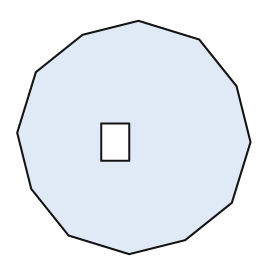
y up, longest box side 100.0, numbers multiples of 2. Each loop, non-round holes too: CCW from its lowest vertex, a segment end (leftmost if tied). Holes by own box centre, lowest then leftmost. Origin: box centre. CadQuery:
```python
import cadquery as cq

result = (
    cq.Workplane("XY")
    .moveTo(-2.0, -50.0)
    .lineTo(22.0, -44.0)
    .lineTo(42.0, -28.0)
    .lineTo(50.0, -2.0)
    .lineTo(44.0, 22.0)
    .lineTo(28.0, 42.0)
    .lineTo(2.0, 50.0)
    .lineTo(-22.0, 44.0)
    .lineTo(-42.0, 28.0)
    .lineTo(-50.0, 2.0)
    .lineTo(-44.0, -22.0)
    .lineTo(-28.0, -42.0)
    .close()
    .moveTo(-14.0, -10.0)
    .lineTo(-2.0, -10.0)
    .lineTo(-2.0, 6.0)
    .lineTo(-14.0, 6.0)
    .close()
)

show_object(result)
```